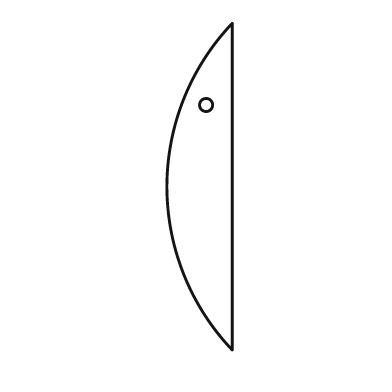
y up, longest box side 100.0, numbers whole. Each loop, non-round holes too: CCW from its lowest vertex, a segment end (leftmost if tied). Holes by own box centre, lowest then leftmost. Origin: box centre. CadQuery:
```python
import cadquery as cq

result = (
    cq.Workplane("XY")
    .moveTo(10.0, -50.0)
    .lineTo(10.0, 50.0)
    .threePointArc((-10.0, 0.0), (10.0, -50.0))
    .close()
    .moveTo(2.0, 25.0)
    .circle(2.0)
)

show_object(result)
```